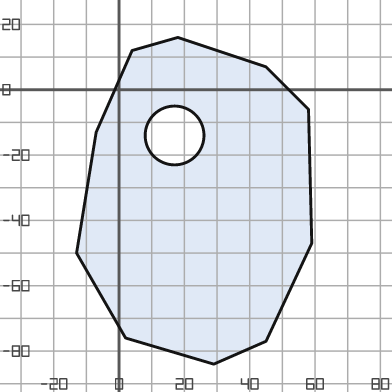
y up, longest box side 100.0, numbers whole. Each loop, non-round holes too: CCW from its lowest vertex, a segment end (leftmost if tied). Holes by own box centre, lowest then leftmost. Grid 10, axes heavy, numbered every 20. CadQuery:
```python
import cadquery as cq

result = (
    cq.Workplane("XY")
    .moveTo(29.0, -84.0)
    .lineTo(45.0, -77.0)
    .lineTo(59.0, -47.0)
    .lineTo(58.0, -6.0)
    .lineTo(45.0, 7.0)
    .lineTo(18.0, 16.0)
    .lineTo(4.0, 12.0)
    .lineTo(-7.0, -13.0)
    .lineTo(-13.0, -50.0)
    .lineTo(2.0, -76.0)
    .close()
    .moveTo(17.0, -14.0)
    .circle(9.0)
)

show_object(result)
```